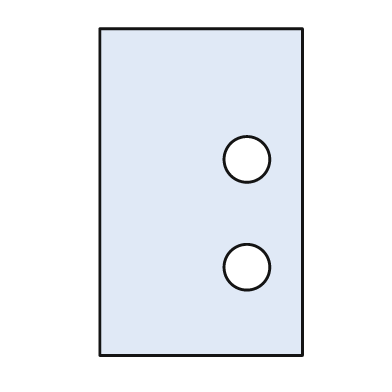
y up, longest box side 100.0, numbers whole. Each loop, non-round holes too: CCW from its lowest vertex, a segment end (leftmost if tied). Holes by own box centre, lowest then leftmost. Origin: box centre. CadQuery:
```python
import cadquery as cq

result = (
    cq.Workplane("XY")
    .moveTo(-31.0, -50.0)
    .lineTo(31.0, -50.0)
    .lineTo(31.0, 50.0)
    .lineTo(-31.0, 50.0)
    .close()
    .moveTo(14.0, -23.0)
    .circle(7.0)
    .moveTo(14.0, 10.0)
    .circle(7.0)
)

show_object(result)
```